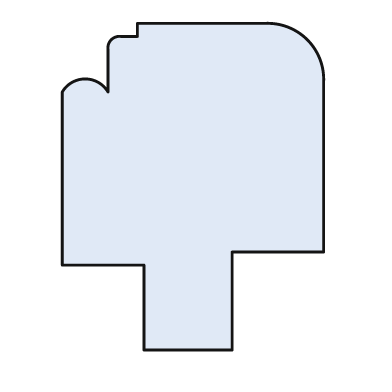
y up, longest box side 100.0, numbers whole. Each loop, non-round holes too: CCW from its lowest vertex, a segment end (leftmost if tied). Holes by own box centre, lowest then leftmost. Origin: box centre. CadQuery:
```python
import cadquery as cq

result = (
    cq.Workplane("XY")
    .moveTo(-15.0, -50.0)
    .lineTo(12.0, -50.0)
    .lineTo(12.0, -20.0)
    .lineTo(40.0, -20.0)
    .lineTo(40.0, 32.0)
    .threePointArc((35.0, 45.0), (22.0, 50.0))
    .lineTo(-17.0, 50.0)
    .lineTo(-17.0, 46.0)
    .lineTo(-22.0, 46.0)
    .threePointArc((-25.0, 45.0), (-26.0, 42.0))
    .lineTo(-26.0, 29.0)
    .threePointArc((-33.0, 33.0), (-40.0, 29.0))
    .lineTo(-40.0, -24.0)
    .lineTo(-15.0, -24.0)
    .close()
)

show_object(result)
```